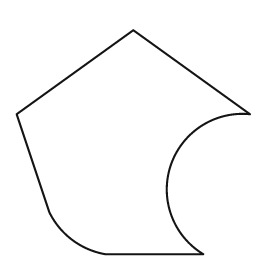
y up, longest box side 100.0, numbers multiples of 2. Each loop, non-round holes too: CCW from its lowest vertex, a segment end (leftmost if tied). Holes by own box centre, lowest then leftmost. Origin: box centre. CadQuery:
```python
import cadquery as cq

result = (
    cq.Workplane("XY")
    .moveTo(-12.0, -48.0)
    .lineTo(30.0, -48.0)
    .threePointArc((16.0, -10.0), (50.0, 12.0))
    .lineTo(0.0, 48.0)
    .lineTo(-50.0, 12.0)
    .lineTo(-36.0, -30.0)
    .threePointArc((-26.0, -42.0), (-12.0, -48.0))
    .close()
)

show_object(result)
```